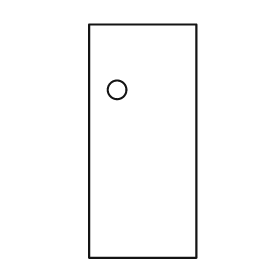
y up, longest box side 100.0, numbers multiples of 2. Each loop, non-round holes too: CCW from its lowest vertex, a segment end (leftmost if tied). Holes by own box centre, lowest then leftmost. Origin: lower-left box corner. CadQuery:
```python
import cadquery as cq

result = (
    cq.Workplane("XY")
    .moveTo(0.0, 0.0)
    .lineTo(46.0, 0.0)
    .lineTo(46.0, 100.0)
    .lineTo(0.0, 100.0)
    .close()
    .moveTo(12.0, 72.0)
    .circle(4.0)
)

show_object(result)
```